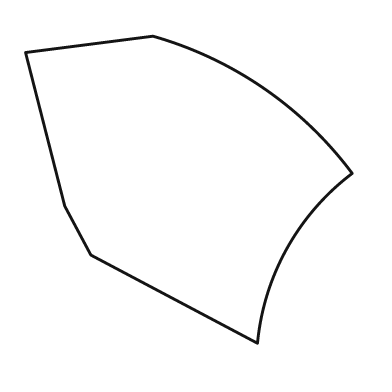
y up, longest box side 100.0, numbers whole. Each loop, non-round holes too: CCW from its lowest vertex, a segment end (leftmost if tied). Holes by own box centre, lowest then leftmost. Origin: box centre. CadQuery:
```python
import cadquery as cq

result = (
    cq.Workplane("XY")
    .moveTo(21.0, -47.0)
    .threePointArc((30.0, -18.0), (50.0, 5.0))
    .threePointArc((23.0, 31.0), (-11.0, 47.0))
    .lineTo(-50.0, 42.0)
    .lineTo(-38.0, -5.0)
    .lineTo(-30.0, -20.0)
    .close()
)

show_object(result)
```